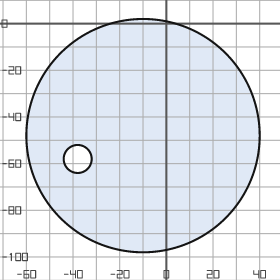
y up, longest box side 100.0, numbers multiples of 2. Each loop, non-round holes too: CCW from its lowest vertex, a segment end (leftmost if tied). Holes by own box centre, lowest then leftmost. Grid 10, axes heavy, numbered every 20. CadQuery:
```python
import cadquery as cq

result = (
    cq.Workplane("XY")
    .moveTo(-10.0, -48.0)
    .circle(50.0)
    .moveTo(-38.0, -58.0)
    .circle(6.0)
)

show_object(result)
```